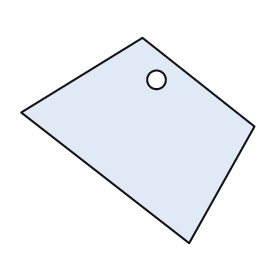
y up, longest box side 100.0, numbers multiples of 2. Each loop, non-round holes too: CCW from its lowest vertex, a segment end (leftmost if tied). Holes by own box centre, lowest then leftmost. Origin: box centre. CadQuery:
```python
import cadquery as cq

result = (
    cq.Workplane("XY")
    .moveTo(22.0, -44.0)
    .lineTo(50.0, 6.0)
    .lineTo(2.0, 44.0)
    .lineTo(-50.0, 12.0)
    .close()
    .moveTo(8.0, 26.0)
    .circle(4.0)
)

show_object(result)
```